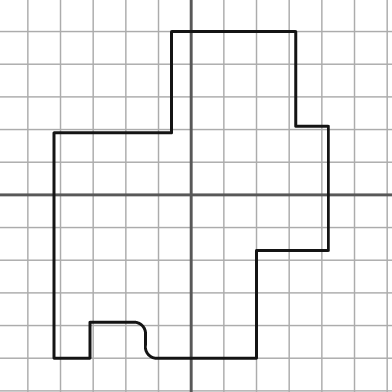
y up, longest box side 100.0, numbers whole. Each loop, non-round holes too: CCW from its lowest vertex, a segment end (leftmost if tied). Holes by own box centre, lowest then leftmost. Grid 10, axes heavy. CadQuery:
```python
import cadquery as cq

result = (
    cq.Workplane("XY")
    .moveTo(-42.0, -50.0)
    .lineTo(-31.0, -50.0)
    .lineTo(-31.0, -39.0)
    .lineTo(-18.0, -39.0)
    .threePointArc((-15.0, -40.0), (-14.0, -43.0))
    .lineTo(-14.0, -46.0)
    .threePointArc((-13.0, -49.0), (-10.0, -50.0))
    .lineTo(20.0, -50.0)
    .lineTo(20.0, -17.0)
    .lineTo(42.0, -17.0)
    .lineTo(42.0, 21.0)
    .lineTo(32.0, 21.0)
    .lineTo(32.0, 50.0)
    .lineTo(-6.0, 50.0)
    .lineTo(-6.0, 19.0)
    .lineTo(-42.0, 19.0)
    .close()
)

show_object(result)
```